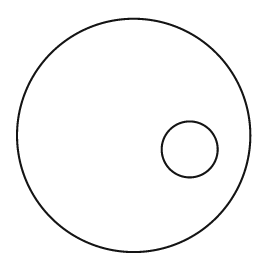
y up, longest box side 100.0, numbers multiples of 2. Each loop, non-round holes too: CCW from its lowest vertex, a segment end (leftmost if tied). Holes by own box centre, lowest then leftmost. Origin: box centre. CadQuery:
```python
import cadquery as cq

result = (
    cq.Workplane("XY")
    .moveTo(0.0, 0.0)
    .circle(50.0)
    .moveTo(24.0, -6.0)
    .circle(12.0)
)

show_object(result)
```